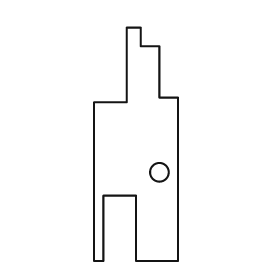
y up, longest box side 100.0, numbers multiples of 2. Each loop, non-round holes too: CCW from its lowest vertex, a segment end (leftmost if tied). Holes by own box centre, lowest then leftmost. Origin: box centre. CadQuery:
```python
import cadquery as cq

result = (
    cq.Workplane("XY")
    .moveTo(-18.0, -50.0)
    .lineTo(-14.0, -50.0)
    .lineTo(-14.0, -22.0)
    .lineTo(0.0, -22.0)
    .lineTo(0.0, -50.0)
    .lineTo(18.0, -50.0)
    .lineTo(18.0, 20.0)
    .lineTo(10.0, 20.0)
    .lineTo(10.0, 42.0)
    .lineTo(2.0, 42.0)
    .lineTo(2.0, 50.0)
    .lineTo(-4.0, 50.0)
    .lineTo(-4.0, 18.0)
    .lineTo(-18.0, 18.0)
    .close()
    .moveTo(10.0, -12.0)
    .circle(4.0)
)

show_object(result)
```